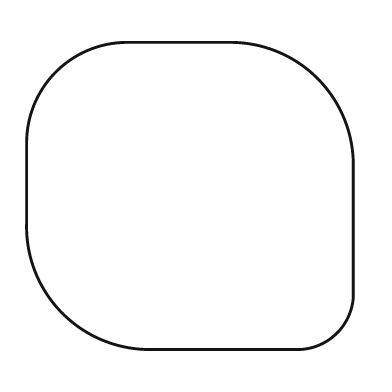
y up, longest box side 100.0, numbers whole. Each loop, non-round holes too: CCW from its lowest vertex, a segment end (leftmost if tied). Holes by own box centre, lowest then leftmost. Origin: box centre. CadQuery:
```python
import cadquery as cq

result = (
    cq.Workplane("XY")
    .moveTo(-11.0, -47.0)
    .lineTo(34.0, -47.0)
    .threePointArc((45.0, -42.0), (50.0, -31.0))
    .lineTo(50.0, 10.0)
    .threePointArc((39.0, 36.0), (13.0, 47.0))
    .lineTo(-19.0, 47.0)
    .threePointArc((-41.0, 38.0), (-50.0, 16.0))
    .lineTo(-50.0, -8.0)
    .threePointArc((-39.0, -36.0), (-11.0, -47.0))
    .close()
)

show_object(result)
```